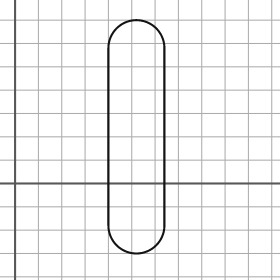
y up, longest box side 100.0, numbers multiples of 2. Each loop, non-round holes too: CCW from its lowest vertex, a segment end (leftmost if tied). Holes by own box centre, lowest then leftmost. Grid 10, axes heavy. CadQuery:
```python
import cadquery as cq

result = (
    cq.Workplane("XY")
    .moveTo(40.0, -18.0)
    .threePointArc((52.0, -30.0), (64.0, -18.0))
    .lineTo(64.0, 58.0)
    .threePointArc((52.0, 70.0), (40.0, 58.0))
    .close()
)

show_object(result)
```